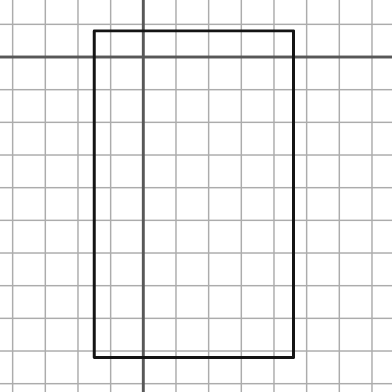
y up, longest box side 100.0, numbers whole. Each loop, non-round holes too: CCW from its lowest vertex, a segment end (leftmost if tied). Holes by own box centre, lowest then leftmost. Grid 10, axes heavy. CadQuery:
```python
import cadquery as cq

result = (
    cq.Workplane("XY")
    .moveTo(-15.0, -92.0)
    .lineTo(46.0, -92.0)
    .lineTo(46.0, 8.0)
    .lineTo(-15.0, 8.0)
    .close()
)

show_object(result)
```